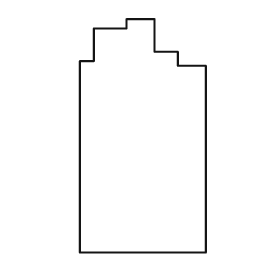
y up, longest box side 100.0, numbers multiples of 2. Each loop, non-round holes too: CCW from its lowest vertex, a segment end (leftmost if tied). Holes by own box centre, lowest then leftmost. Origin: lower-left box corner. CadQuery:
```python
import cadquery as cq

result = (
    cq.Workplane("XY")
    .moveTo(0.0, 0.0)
    .lineTo(54.0, 0.0)
    .lineTo(54.0, 80.0)
    .lineTo(42.0, 80.0)
    .lineTo(42.0, 86.0)
    .lineTo(32.0, 86.0)
    .lineTo(32.0, 100.0)
    .lineTo(20.0, 100.0)
    .lineTo(20.0, 96.0)
    .lineTo(6.0, 96.0)
    .lineTo(6.0, 82.0)
    .lineTo(0.0, 82.0)
    .close()
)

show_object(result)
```